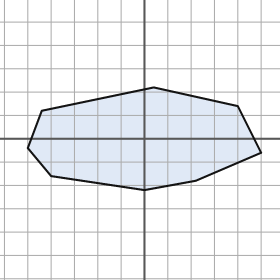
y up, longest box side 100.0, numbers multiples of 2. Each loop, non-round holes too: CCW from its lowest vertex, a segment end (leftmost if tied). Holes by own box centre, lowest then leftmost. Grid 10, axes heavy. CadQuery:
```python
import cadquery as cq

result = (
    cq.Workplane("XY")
    .moveTo(0.0, -22.0)
    .lineTo(22.0, -18.0)
    .lineTo(50.0, -6.0)
    .lineTo(40.0, 14.0)
    .lineTo(4.0, 22.0)
    .lineTo(-44.0, 12.0)
    .lineTo(-50.0, -4.0)
    .lineTo(-40.0, -16.0)
    .close()
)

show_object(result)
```